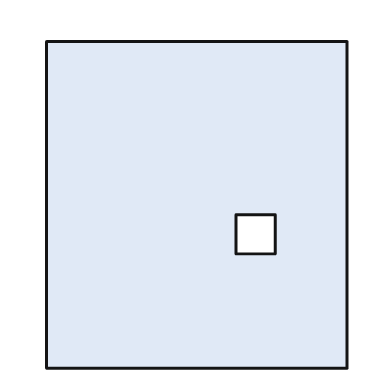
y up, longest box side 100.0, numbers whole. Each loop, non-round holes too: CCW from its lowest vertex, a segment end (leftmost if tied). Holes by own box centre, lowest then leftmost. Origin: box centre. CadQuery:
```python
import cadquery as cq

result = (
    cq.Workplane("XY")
    .moveTo(-46.0, -50.0)
    .lineTo(46.0, -50.0)
    .lineTo(46.0, 50.0)
    .lineTo(-46.0, 50.0)
    .close()
    .moveTo(12.0, -15.0)
    .lineTo(24.0, -15.0)
    .lineTo(24.0, -3.0)
    .lineTo(12.0, -3.0)
    .close()
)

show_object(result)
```